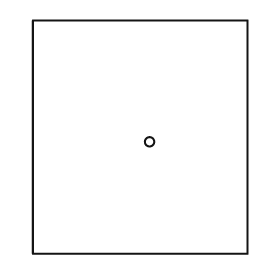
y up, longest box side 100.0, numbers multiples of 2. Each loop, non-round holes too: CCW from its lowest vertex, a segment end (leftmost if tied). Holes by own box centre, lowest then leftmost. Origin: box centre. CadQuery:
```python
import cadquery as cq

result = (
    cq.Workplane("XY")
    .moveTo(-46.0, -50.0)
    .lineTo(46.0, -50.0)
    .lineTo(46.0, 50.0)
    .lineTo(-46.0, 50.0)
    .close()
    .moveTo(4.0, -2.0)
    .circle(2.0)
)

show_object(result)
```